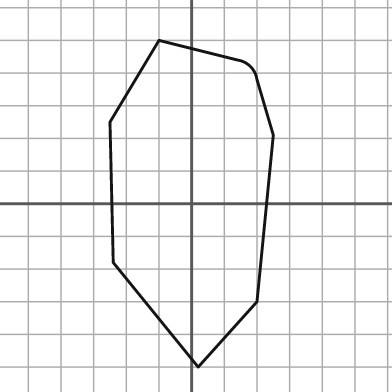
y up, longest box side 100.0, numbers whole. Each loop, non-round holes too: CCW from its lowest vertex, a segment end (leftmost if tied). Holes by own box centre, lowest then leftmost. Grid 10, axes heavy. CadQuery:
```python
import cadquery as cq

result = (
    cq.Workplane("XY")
    .moveTo(2.0, -50.0)
    .lineTo(20.0, -30.0)
    .lineTo(25.0, 21.0)
    .lineTo(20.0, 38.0)
    .threePointArc((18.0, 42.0), (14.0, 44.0))
    .lineTo(-10.0, 50.0)
    .lineTo(-25.0, 25.0)
    .lineTo(-24.0, -18.0)
    .close()
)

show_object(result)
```